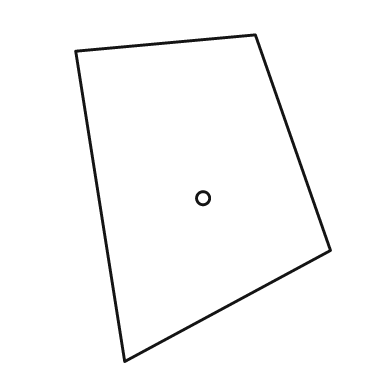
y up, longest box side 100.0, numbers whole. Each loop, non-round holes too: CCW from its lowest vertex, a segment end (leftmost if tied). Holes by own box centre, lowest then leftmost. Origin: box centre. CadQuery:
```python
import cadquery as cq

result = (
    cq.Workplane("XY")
    .moveTo(-24.0, -50.0)
    .lineTo(39.0, -16.0)
    .lineTo(16.0, 50.0)
    .lineTo(-39.0, 45.0)
    .close()
    .moveTo(0.0, 0.0)
    .circle(2.0)
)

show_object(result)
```